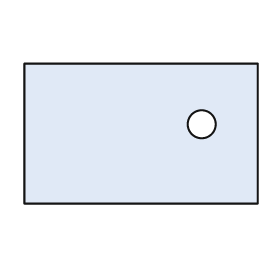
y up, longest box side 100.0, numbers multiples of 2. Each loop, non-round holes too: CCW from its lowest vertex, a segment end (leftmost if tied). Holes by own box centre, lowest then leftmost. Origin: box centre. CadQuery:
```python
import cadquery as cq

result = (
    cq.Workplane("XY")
    .moveTo(-50.0, -30.0)
    .lineTo(50.0, -30.0)
    .lineTo(50.0, 30.0)
    .lineTo(-50.0, 30.0)
    .close()
    .moveTo(26.0, 4.0)
    .circle(6.0)
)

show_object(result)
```